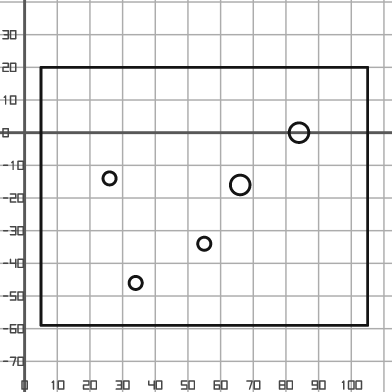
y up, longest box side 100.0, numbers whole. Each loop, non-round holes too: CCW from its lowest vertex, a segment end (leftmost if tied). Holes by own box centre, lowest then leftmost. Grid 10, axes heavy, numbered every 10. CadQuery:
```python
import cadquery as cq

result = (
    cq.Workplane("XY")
    .moveTo(5.0, -59.0)
    .lineTo(105.0, -59.0)
    .lineTo(105.0, 20.0)
    .lineTo(5.0, 20.0)
    .close()
    .moveTo(34.0, -46.0)
    .circle(2.0)
    .moveTo(55.0, -34.0)
    .circle(2.0)
    .moveTo(66.0, -16.0)
    .circle(3.0)
    .moveTo(26.0, -14.0)
    .circle(2.0)
    .moveTo(84.0, 0.0)
    .circle(3.0)
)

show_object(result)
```